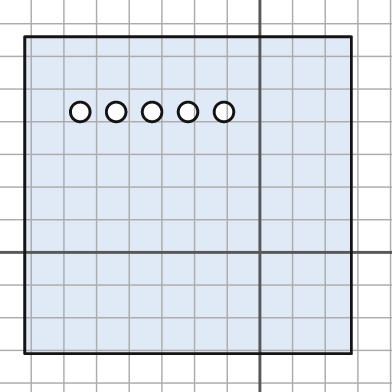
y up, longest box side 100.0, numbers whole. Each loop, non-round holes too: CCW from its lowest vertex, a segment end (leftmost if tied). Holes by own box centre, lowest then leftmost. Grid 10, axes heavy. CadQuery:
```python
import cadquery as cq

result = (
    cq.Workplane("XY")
    .moveTo(-72.0, -31.0)
    .lineTo(28.0, -31.0)
    .lineTo(28.0, 66.0)
    .lineTo(-72.0, 66.0)
    .close()
    .moveTo(-55.0, 43.0)
    .circle(3.0)
    .moveTo(-44.0, 43.0)
    .circle(3.0)
    .moveTo(-33.0, 43.0)
    .circle(3.0)
    .moveTo(-22.0, 43.0)
    .circle(3.0)
    .moveTo(-11.0, 43.0)
    .circle(3.0)
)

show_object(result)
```